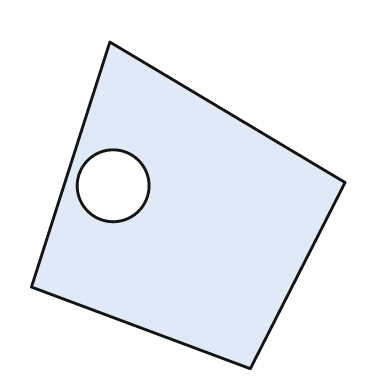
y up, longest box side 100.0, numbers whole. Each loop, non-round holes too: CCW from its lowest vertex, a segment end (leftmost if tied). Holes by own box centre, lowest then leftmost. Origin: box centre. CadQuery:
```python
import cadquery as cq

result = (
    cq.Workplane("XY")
    .moveTo(19.0, -50.0)
    .lineTo(48.0, 7.0)
    .lineTo(-24.0, 50.0)
    .lineTo(-48.0, -25.0)
    .close()
    .moveTo(-23.0, 6.0)
    .circle(11.0)
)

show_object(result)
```